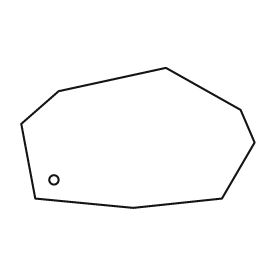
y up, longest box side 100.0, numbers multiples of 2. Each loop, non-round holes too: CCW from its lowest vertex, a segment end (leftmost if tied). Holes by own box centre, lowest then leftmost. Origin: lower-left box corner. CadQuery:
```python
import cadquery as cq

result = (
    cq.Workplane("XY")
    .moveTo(48.0, 0.0)
    .lineTo(86.0, 4.0)
    .lineTo(100.0, 28.0)
    .lineTo(94.0, 42.0)
    .lineTo(62.0, 60.0)
    .lineTo(16.0, 50.0)
    .lineTo(0.0, 36.0)
    .lineTo(6.0, 4.0)
    .close()
    .moveTo(14.0, 12.0)
    .circle(2.0)
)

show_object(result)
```